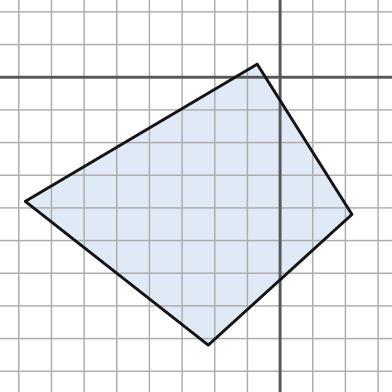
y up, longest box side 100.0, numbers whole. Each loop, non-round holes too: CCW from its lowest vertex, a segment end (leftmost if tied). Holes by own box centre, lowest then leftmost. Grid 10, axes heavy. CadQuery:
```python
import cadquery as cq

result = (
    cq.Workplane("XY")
    .moveTo(-22.0, -82.0)
    .lineTo(22.0, -42.0)
    .lineTo(-7.0, 4.0)
    .lineTo(-78.0, -38.0)
    .close()
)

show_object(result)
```